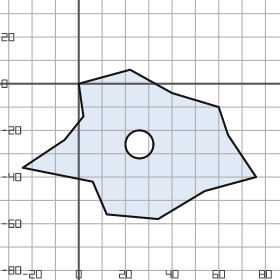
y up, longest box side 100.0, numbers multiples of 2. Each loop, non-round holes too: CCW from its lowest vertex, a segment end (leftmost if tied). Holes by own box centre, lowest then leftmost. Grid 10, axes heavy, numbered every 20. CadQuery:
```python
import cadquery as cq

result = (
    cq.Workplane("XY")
    .moveTo(34.0, -58.0)
    .lineTo(54.0, -46.0)
    .lineTo(76.0, -40.0)
    .lineTo(64.0, -22.0)
    .lineTo(60.0, -10.0)
    .lineTo(40.0, -4.0)
    .lineTo(22.0, 6.0)
    .lineTo(0.0, 0.0)
    .lineTo(2.0, -14.0)
    .lineTo(-6.0, -24.0)
    .lineTo(-24.0, -36.0)
    .lineTo(6.0, -42.0)
    .lineTo(12.0, -56.0)
    .close()
    .moveTo(26.0, -26.0)
    .circle(6.0)
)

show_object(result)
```